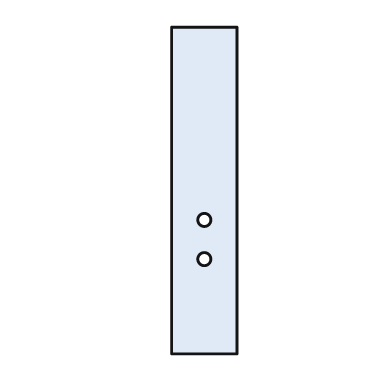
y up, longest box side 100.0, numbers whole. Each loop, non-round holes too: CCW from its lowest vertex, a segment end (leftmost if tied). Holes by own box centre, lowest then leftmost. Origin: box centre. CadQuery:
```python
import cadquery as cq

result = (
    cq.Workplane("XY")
    .moveTo(-10.0, -50.0)
    .lineTo(10.0, -50.0)
    .lineTo(10.0, 50.0)
    .lineTo(-10.0, 50.0)
    .close()
    .moveTo(0.0, -21.0)
    .circle(2.0)
    .moveTo(0.0, -9.0)
    .circle(2.0)
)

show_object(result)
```